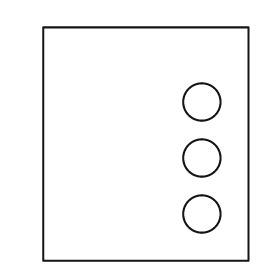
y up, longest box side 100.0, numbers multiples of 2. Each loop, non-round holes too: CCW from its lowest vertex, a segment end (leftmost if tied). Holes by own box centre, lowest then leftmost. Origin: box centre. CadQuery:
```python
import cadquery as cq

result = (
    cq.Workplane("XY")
    .moveTo(-44.0, -50.0)
    .lineTo(44.0, -50.0)
    .lineTo(44.0, 50.0)
    .lineTo(-44.0, 50.0)
    .close()
    .moveTo(24.0, -30.0)
    .circle(8.0)
    .moveTo(24.0, -6.0)
    .circle(8.0)
    .moveTo(24.0, 18.0)
    .circle(8.0)
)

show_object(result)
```